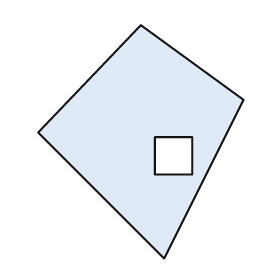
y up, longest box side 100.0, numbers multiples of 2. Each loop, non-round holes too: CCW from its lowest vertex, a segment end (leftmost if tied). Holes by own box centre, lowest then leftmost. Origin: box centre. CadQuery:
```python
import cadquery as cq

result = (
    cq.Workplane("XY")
    .moveTo(10.0, -50.0)
    .lineTo(44.0, 18.0)
    .lineTo(0.0, 50.0)
    .lineTo(-44.0, 4.0)
    .close()
    .moveTo(6.0, -14.0)
    .lineTo(22.0, -14.0)
    .lineTo(22.0, 2.0)
    .lineTo(6.0, 2.0)
    .close()
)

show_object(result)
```